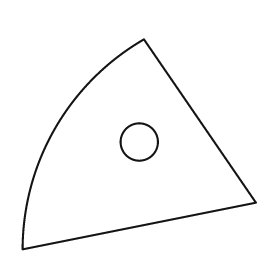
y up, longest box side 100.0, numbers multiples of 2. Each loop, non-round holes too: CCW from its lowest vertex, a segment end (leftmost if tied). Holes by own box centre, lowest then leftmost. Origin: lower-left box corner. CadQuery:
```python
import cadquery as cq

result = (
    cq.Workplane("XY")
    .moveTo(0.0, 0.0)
    .lineTo(100.0, 20.0)
    .lineTo(52.0, 90.0)
    .threePointArc((14.0, 52.0), (0.0, 0.0))
    .close()
    .moveTo(50.0, 46.0)
    .circle(8.0)
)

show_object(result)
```